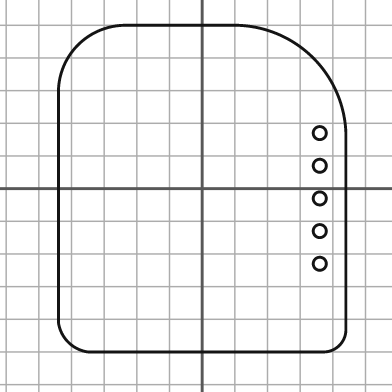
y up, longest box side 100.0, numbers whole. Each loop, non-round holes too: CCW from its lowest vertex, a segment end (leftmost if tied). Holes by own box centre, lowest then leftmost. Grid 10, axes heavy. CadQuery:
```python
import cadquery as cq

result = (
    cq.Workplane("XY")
    .moveTo(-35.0, -50.0)
    .lineTo(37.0, -50.0)
    .threePointArc((42.0, -48.0), (44.0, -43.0))
    .lineTo(44.0, 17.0)
    .threePointArc((34.0, 40.0), (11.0, 50.0))
    .lineTo(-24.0, 50.0)
    .threePointArc((-38.0, 44.0), (-44.0, 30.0))
    .lineTo(-44.0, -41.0)
    .threePointArc((-41.0, -47.0), (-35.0, -50.0))
    .close()
    .moveTo(36.0, -23.0)
    .circle(2.0)
    .moveTo(36.0, -13.0)
    .circle(2.0)
    .moveTo(36.0, -3.0)
    .circle(2.0)
    .moveTo(36.0, 7.0)
    .circle(2.0)
    .moveTo(36.0, 17.0)
    .circle(2.0)
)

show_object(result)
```